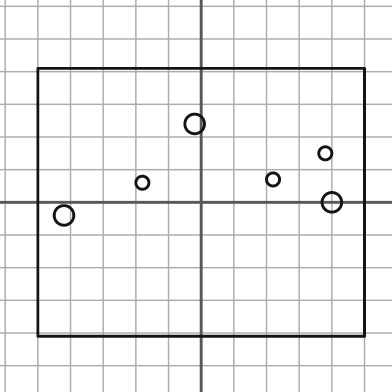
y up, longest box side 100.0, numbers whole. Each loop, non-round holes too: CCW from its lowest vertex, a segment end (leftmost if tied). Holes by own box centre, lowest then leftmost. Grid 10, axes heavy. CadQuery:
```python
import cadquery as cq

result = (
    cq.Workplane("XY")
    .moveTo(-50.0, -41.0)
    .lineTo(50.0, -41.0)
    .lineTo(50.0, 41.0)
    .lineTo(-50.0, 41.0)
    .close()
    .moveTo(-42.0, -4.0)
    .circle(3.0)
    .moveTo(40.0, 0.0)
    .circle(3.0)
    .moveTo(-18.0, 6.0)
    .circle(2.0)
    .moveTo(22.0, 7.0)
    .circle(2.0)
    .moveTo(38.0, 15.0)
    .circle(2.0)
    .moveTo(-2.0, 24.0)
    .circle(3.0)
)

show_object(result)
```